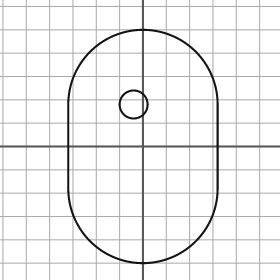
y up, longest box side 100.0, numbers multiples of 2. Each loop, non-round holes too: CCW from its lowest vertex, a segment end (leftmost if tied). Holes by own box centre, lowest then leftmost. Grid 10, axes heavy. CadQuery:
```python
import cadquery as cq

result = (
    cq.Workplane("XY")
    .moveTo(-32.0, -18.0)
    .threePointArc((0.0, -50.0), (32.0, -18.0))
    .lineTo(32.0, 18.0)
    .threePointArc((0.0, 50.0), (-32.0, 18.0))
    .close()
    .moveTo(-4.0, 18.0)
    .circle(6.0)
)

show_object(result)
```